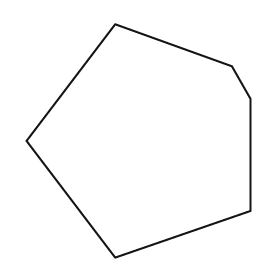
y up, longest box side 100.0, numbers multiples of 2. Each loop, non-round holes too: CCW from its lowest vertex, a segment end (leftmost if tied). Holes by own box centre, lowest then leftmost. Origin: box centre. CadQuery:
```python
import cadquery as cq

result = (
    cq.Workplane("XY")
    .moveTo(-10.0, -50.0)
    .lineTo(48.0, -30.0)
    .lineTo(48.0, 18.0)
    .lineTo(40.0, 32.0)
    .lineTo(-10.0, 50.0)
    .lineTo(-48.0, 0.0)
    .close()
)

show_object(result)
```